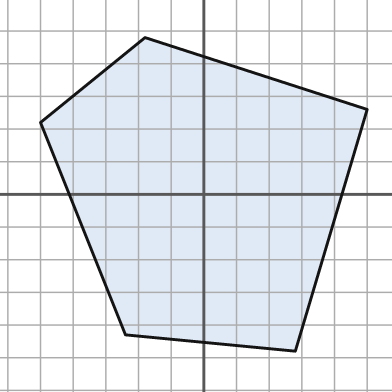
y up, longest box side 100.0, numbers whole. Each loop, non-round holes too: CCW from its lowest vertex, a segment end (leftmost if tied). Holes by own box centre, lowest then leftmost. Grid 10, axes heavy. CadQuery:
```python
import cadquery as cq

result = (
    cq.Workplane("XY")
    .moveTo(28.0, -48.0)
    .lineTo(50.0, 26.0)
    .lineTo(-18.0, 48.0)
    .lineTo(-50.0, 22.0)
    .lineTo(-24.0, -43.0)
    .close()
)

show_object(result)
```